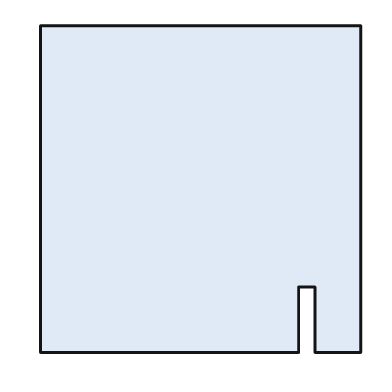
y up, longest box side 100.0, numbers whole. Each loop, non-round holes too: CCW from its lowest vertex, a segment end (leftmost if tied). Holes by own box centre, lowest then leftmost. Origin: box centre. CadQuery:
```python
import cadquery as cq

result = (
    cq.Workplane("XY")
    .moveTo(-49.0, -50.0)
    .lineTo(30.0, -50.0)
    .lineTo(30.0, -30.0)
    .lineTo(35.0, -30.0)
    .lineTo(35.0, -50.0)
    .lineTo(49.0, -50.0)
    .lineTo(49.0, 50.0)
    .lineTo(-49.0, 50.0)
    .close()
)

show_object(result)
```